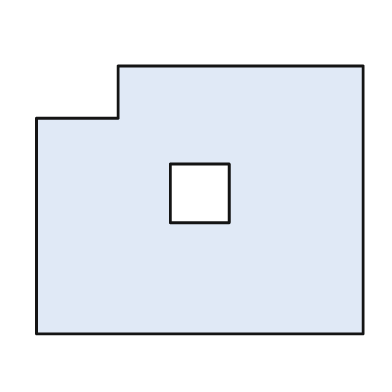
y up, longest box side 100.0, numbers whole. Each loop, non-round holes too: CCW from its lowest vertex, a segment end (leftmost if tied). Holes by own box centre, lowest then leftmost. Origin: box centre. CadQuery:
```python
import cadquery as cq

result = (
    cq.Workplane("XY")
    .moveTo(-50.0, -41.0)
    .lineTo(50.0, -41.0)
    .lineTo(50.0, 41.0)
    .lineTo(-25.0, 41.0)
    .lineTo(-25.0, 25.0)
    .lineTo(-50.0, 25.0)
    .close()
    .moveTo(-9.0, -7.0)
    .lineTo(9.0, -7.0)
    .lineTo(9.0, 11.0)
    .lineTo(-9.0, 11.0)
    .close()
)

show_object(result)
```